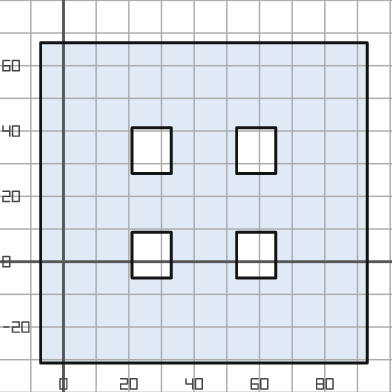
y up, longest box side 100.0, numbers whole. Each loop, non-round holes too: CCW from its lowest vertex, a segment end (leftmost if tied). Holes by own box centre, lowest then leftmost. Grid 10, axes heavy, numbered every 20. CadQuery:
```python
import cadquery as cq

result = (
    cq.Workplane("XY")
    .moveTo(-7.0, -31.0)
    .lineTo(93.0, -31.0)
    .lineTo(93.0, 67.0)
    .lineTo(-7.0, 67.0)
    .close()
    .moveTo(21.0, -5.0)
    .lineTo(33.0, -5.0)
    .lineTo(33.0, 9.0)
    .lineTo(21.0, 9.0)
    .close()
    .moveTo(53.0, -5.0)
    .lineTo(65.0, -5.0)
    .lineTo(65.0, 9.0)
    .lineTo(53.0, 9.0)
    .close()
    .moveTo(21.0, 27.0)
    .lineTo(33.0, 27.0)
    .lineTo(33.0, 41.0)
    .lineTo(21.0, 41.0)
    .close()
    .moveTo(53.0, 27.0)
    .lineTo(65.0, 27.0)
    .lineTo(65.0, 41.0)
    .lineTo(53.0, 41.0)
    .close()
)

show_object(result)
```